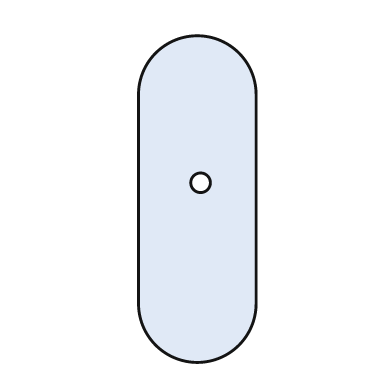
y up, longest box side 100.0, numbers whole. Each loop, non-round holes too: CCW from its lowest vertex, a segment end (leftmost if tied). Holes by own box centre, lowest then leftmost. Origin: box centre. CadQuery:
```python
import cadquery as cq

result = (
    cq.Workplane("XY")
    .moveTo(-18.0, -32.0)
    .threePointArc((0.0, -50.0), (18.0, -32.0))
    .lineTo(18.0, 32.0)
    .threePointArc((0.0, 50.0), (-18.0, 32.0))
    .close()
    .moveTo(1.0, 5.0)
    .circle(3.0)
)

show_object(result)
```